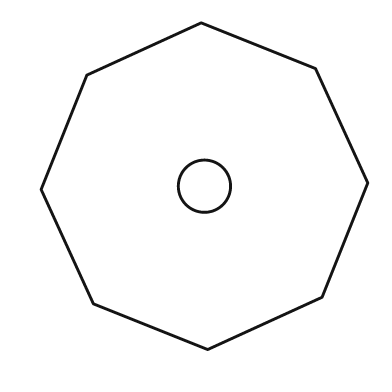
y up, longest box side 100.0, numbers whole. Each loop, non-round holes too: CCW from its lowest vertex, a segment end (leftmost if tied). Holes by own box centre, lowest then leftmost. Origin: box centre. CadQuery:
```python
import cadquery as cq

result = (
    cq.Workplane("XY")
    .moveTo(1.0, -50.0)
    .lineTo(36.0, -34.0)
    .lineTo(50.0, 1.0)
    .lineTo(34.0, 36.0)
    .lineTo(-1.0, 50.0)
    .lineTo(-36.0, 34.0)
    .lineTo(-50.0, -1.0)
    .lineTo(-34.0, -36.0)
    .close()
    .moveTo(0.0, 0.0)
    .circle(8.0)
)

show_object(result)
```